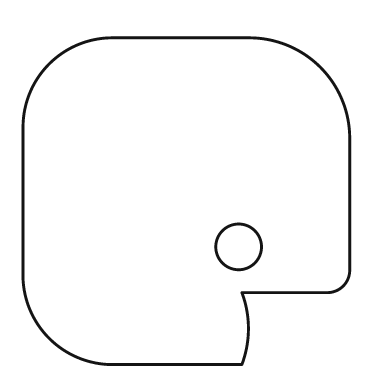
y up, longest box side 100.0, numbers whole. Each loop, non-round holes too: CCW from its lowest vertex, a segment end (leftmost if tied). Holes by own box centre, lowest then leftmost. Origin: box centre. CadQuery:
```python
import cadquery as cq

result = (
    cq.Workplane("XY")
    .moveTo(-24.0, -50.0)
    .lineTo(17.0, -50.0)
    .threePointArc((19.0, -39.0), (17.0, -28.0))
    .lineTo(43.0, -28.0)
    .threePointArc((48.0, -26.0), (50.0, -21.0))
    .lineTo(50.0, 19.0)
    .threePointArc((41.0, 41.0), (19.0, 50.0))
    .lineTo(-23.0, 50.0)
    .threePointArc((-42.0, 42.0), (-50.0, 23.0))
    .lineTo(-50.0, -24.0)
    .threePointArc((-42.0, -42.0), (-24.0, -50.0))
    .close()
    .moveTo(16.0, -14.0)
    .circle(7.0)
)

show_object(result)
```